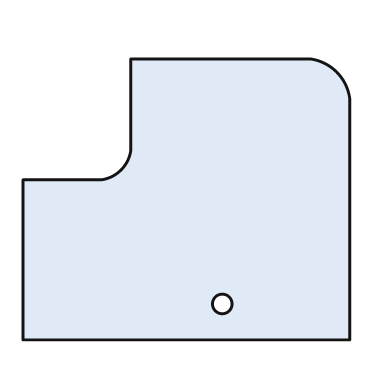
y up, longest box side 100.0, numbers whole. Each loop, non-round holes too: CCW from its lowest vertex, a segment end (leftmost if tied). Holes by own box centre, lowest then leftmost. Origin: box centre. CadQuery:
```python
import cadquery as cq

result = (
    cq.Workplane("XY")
    .moveTo(-50.0, -43.0)
    .lineTo(50.0, -43.0)
    .lineTo(50.0, 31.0)
    .threePointArc((46.0, 39.0), (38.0, 43.0))
    .lineTo(-17.0, 43.0)
    .lineTo(-17.0, 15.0)
    .threePointArc((-20.0, 9.0), (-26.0, 6.0))
    .lineTo(-50.0, 6.0)
    .close()
    .moveTo(11.0, -32.0)
    .circle(3.0)
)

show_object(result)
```